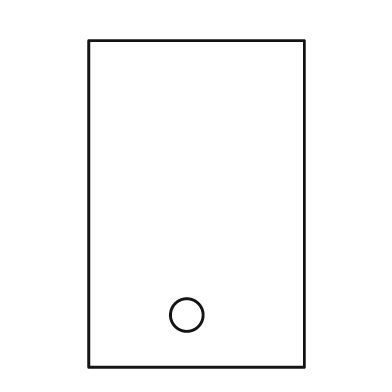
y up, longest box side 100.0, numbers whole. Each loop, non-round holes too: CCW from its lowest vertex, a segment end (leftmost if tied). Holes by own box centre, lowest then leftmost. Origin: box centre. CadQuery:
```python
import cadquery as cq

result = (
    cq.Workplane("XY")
    .moveTo(-33.0, -50.0)
    .lineTo(33.0, -50.0)
    .lineTo(33.0, 50.0)
    .lineTo(-33.0, 50.0)
    .close()
    .moveTo(-3.0, -34.0)
    .circle(5.0)
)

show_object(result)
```